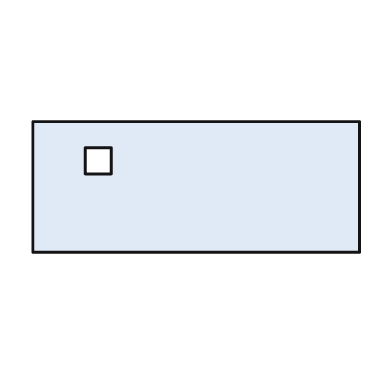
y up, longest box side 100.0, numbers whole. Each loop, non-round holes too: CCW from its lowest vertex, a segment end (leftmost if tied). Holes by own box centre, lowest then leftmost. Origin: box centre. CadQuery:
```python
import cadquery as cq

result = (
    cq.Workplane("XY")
    .moveTo(-50.0, -20.0)
    .lineTo(50.0, -20.0)
    .lineTo(50.0, 20.0)
    .lineTo(-50.0, 20.0)
    .close()
    .moveTo(-34.0, 4.0)
    .lineTo(-26.0, 4.0)
    .lineTo(-26.0, 12.0)
    .lineTo(-34.0, 12.0)
    .close()
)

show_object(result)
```